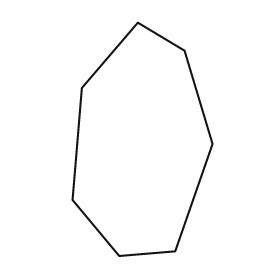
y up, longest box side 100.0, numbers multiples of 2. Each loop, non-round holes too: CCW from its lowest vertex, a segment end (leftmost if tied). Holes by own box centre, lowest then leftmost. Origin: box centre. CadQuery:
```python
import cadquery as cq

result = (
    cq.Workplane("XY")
    .moveTo(-10.0, -50.0)
    .lineTo(14.0, -48.0)
    .lineTo(30.0, -2.0)
    .lineTo(18.0, 38.0)
    .lineTo(-2.0, 50.0)
    .lineTo(-26.0, 22.0)
    .lineTo(-30.0, -26.0)
    .close()
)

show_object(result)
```